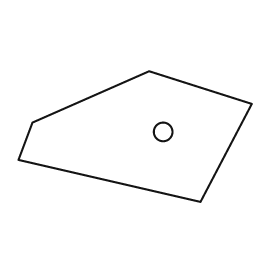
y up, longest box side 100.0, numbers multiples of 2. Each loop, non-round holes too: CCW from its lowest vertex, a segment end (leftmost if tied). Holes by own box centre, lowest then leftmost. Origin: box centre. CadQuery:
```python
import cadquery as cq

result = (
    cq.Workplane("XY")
    .moveTo(28.0, -28.0)
    .lineTo(50.0, 14.0)
    .lineTo(6.0, 28.0)
    .lineTo(-44.0, 6.0)
    .lineTo(-50.0, -10.0)
    .close()
    .moveTo(12.0, 2.0)
    .circle(4.0)
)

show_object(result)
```